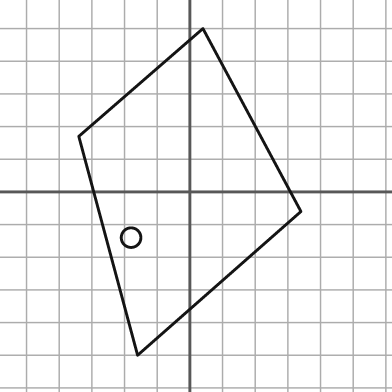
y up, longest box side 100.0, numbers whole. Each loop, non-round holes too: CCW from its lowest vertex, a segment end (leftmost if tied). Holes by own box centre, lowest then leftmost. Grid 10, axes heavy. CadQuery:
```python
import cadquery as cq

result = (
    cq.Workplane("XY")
    .moveTo(-16.0, -50.0)
    .lineTo(34.0, -6.0)
    .lineTo(4.0, 50.0)
    .lineTo(-34.0, 17.0)
    .close()
    .moveTo(-18.0, -14.0)
    .circle(3.0)
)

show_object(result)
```